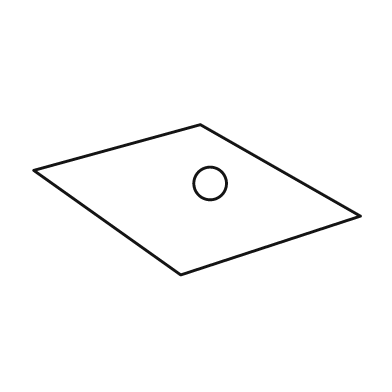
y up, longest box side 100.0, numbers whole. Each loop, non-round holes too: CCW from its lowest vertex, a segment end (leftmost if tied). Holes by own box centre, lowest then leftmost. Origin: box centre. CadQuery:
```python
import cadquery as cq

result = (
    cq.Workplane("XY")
    .moveTo(-5.0, -23.0)
    .lineTo(50.0, -5.0)
    .lineTo(1.0, 23.0)
    .lineTo(-50.0, 9.0)
    .close()
    .moveTo(4.0, 5.0)
    .circle(5.0)
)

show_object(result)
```